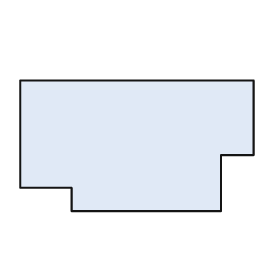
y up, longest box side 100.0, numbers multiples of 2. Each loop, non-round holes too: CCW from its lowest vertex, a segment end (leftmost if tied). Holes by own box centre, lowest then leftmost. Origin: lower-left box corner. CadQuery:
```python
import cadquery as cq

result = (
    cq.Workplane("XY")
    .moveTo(22.0, 0.0)
    .lineTo(86.0, 0.0)
    .lineTo(86.0, 24.0)
    .lineTo(100.0, 24.0)
    .lineTo(100.0, 56.0)
    .lineTo(0.0, 56.0)
    .lineTo(0.0, 10.0)
    .lineTo(22.0, 10.0)
    .close()
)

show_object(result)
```